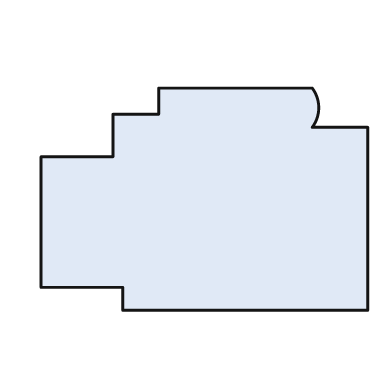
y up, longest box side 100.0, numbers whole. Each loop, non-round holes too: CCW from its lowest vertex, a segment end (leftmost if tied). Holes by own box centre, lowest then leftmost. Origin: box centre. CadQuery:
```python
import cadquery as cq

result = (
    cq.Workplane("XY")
    .moveTo(-25.0, -34.0)
    .lineTo(50.0, -34.0)
    .lineTo(50.0, 22.0)
    .lineTo(33.0, 22.0)
    .threePointArc((35.0, 28.0), (33.0, 34.0))
    .lineTo(-14.0, 34.0)
    .lineTo(-14.0, 26.0)
    .lineTo(-28.0, 26.0)
    .lineTo(-28.0, 13.0)
    .lineTo(-50.0, 13.0)
    .lineTo(-50.0, -27.0)
    .lineTo(-25.0, -27.0)
    .close()
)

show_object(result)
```